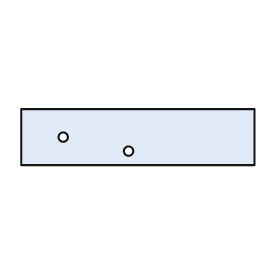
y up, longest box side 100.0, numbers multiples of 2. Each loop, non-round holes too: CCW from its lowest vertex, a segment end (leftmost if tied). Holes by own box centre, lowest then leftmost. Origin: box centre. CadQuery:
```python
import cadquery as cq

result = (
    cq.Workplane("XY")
    .moveTo(-50.0, -12.0)
    .lineTo(50.0, -12.0)
    .lineTo(50.0, 12.0)
    .lineTo(-50.0, 12.0)
    .close()
    .moveTo(-4.0, -6.0)
    .circle(2.0)
    .moveTo(-32.0, 0.0)
    .circle(2.0)
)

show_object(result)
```